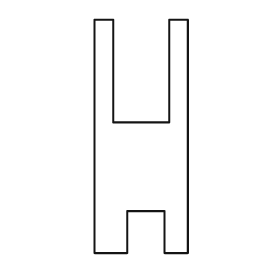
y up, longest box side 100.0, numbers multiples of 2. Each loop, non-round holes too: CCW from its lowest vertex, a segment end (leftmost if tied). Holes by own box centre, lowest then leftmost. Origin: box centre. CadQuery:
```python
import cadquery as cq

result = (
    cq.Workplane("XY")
    .moveTo(-20.0, -50.0)
    .lineTo(-6.0, -50.0)
    .lineTo(-6.0, -32.0)
    .lineTo(10.0, -32.0)
    .lineTo(10.0, -50.0)
    .lineTo(20.0, -50.0)
    .lineTo(20.0, 50.0)
    .lineTo(12.0, 50.0)
    .lineTo(12.0, 6.0)
    .lineTo(-12.0, 6.0)
    .lineTo(-12.0, 50.0)
    .lineTo(-20.0, 50.0)
    .close()
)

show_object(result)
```